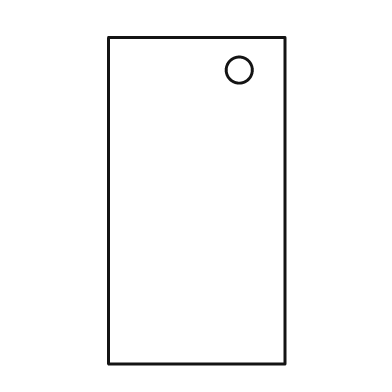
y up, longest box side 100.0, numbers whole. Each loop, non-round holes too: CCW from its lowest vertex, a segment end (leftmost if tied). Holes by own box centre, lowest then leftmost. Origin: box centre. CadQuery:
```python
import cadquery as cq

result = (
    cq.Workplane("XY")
    .moveTo(-27.0, -50.0)
    .lineTo(27.0, -50.0)
    .lineTo(27.0, 50.0)
    .lineTo(-27.0, 50.0)
    .close()
    .moveTo(13.0, 40.0)
    .circle(4.0)
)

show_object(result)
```